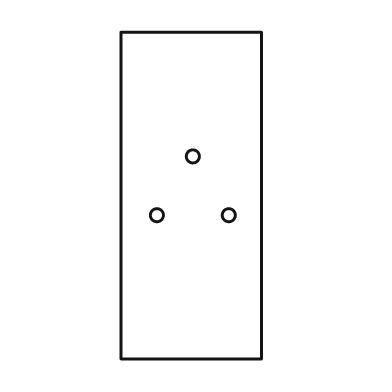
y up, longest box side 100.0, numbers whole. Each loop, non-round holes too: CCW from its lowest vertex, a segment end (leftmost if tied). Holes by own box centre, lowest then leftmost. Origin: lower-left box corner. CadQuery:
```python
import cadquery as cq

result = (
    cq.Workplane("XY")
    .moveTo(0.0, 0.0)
    .lineTo(43.0, 0.0)
    .lineTo(43.0, 100.0)
    .lineTo(0.0, 100.0)
    .close()
    .moveTo(11.0, 44.0)
    .circle(2.0)
    .moveTo(33.0, 44.0)
    .circle(2.0)
    .moveTo(22.0, 62.0)
    .circle(2.0)
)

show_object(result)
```